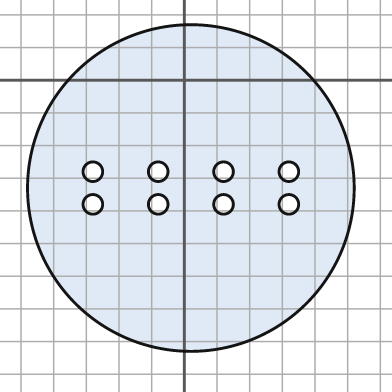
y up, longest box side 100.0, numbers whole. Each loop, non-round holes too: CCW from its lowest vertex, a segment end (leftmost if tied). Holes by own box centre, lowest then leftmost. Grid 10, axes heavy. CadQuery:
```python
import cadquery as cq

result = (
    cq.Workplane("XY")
    .moveTo(2.0, -33.0)
    .circle(50.0)
    .moveTo(-28.0, -38.0)
    .circle(3.0)
    .moveTo(-8.0, -38.0)
    .circle(3.0)
    .moveTo(12.0, -38.0)
    .circle(3.0)
    .moveTo(32.0, -38.0)
    .circle(3.0)
    .moveTo(-28.0, -28.0)
    .circle(3.0)
    .moveTo(-8.0, -28.0)
    .circle(3.0)
    .moveTo(12.0, -28.0)
    .circle(3.0)
    .moveTo(32.0, -28.0)
    .circle(3.0)
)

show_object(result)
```